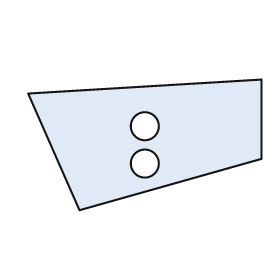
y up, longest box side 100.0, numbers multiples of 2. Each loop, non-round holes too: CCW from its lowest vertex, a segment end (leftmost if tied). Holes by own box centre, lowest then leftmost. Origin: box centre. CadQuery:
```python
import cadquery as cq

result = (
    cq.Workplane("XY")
    .moveTo(-28.0, -28.0)
    .lineTo(50.0, -6.0)
    .lineTo(50.0, 28.0)
    .lineTo(-50.0, 22.0)
    .close()
    .moveTo(0.0, -8.0)
    .circle(6.0)
    .moveTo(0.0, 8.0)
    .circle(6.0)
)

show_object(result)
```